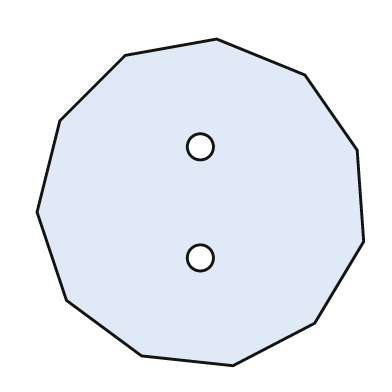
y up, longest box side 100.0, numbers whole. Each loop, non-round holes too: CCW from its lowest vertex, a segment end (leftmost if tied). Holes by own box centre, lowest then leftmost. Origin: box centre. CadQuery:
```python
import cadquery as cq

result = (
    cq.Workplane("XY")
    .moveTo(10.0, -50.0)
    .lineTo(35.0, -37.0)
    .lineTo(50.0, -12.0)
    .lineTo(48.0, 16.0)
    .lineTo(32.0, 39.0)
    .lineTo(5.0, 50.0)
    .lineTo(-23.0, 45.0)
    .lineTo(-43.0, 25.0)
    .lineTo(-50.0, -3.0)
    .lineTo(-41.0, -30.0)
    .lineTo(-18.0, -47.0)
    .close()
    .moveTo(0.0, -17.0)
    .circle(4.0)
    .moveTo(0.0, 17.0)
    .circle(4.0)
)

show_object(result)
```